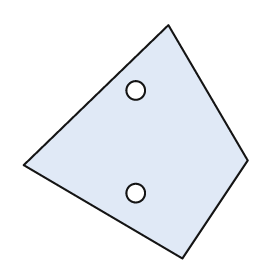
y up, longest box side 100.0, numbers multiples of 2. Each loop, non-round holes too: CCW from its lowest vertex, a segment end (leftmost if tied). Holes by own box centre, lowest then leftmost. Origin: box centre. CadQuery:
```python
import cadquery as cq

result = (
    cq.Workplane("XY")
    .moveTo(20.0, -50.0)
    .lineTo(48.0, -8.0)
    .lineTo(14.0, 50.0)
    .lineTo(-48.0, -10.0)
    .close()
    .moveTo(0.0, -22.0)
    .circle(4.0)
    .moveTo(0.0, 22.0)
    .circle(4.0)
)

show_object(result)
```